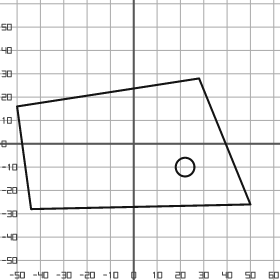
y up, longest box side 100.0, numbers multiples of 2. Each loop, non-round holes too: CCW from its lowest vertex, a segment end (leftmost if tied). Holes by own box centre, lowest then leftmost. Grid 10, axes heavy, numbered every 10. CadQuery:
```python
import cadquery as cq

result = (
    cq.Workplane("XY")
    .moveTo(-44.0, -28.0)
    .lineTo(50.0, -26.0)
    .lineTo(28.0, 28.0)
    .lineTo(-50.0, 16.0)
    .close()
    .moveTo(22.0, -10.0)
    .circle(4.0)
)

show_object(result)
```